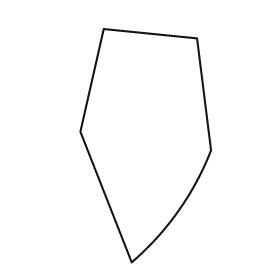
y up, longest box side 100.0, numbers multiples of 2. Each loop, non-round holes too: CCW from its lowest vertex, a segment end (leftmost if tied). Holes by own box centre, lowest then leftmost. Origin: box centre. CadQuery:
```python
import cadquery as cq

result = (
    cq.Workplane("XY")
    .moveTo(-6.0, -50.0)
    .threePointArc((14.0, -28.0), (28.0, -2.0))
    .lineTo(22.0, 46.0)
    .lineTo(-18.0, 50.0)
    .lineTo(-28.0, 6.0)
    .close()
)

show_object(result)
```